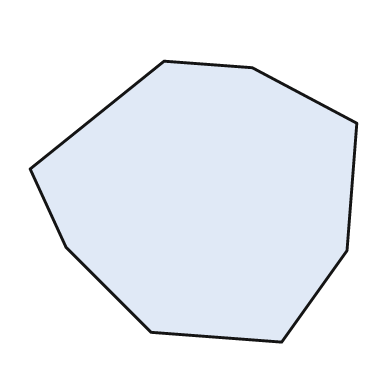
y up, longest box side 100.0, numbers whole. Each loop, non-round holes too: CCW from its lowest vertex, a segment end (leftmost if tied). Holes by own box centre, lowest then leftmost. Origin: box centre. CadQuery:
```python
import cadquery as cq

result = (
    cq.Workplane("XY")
    .moveTo(27.0, -43.0)
    .lineTo(47.0, -15.0)
    .lineTo(50.0, 24.0)
    .lineTo(18.0, 41.0)
    .lineTo(-9.0, 43.0)
    .lineTo(-50.0, 10.0)
    .lineTo(-39.0, -14.0)
    .lineTo(-13.0, -40.0)
    .close()
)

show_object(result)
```